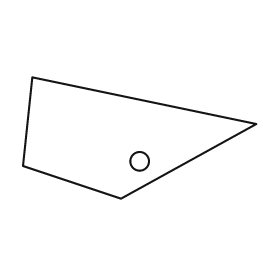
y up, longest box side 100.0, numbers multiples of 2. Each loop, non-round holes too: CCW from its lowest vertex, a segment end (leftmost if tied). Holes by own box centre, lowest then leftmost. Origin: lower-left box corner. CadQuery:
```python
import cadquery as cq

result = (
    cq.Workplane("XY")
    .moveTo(42.0, 0.0)
    .lineTo(100.0, 32.0)
    .lineTo(4.0, 52.0)
    .lineTo(0.0, 14.0)
    .close()
    .moveTo(50.0, 16.0)
    .circle(4.0)
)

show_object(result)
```